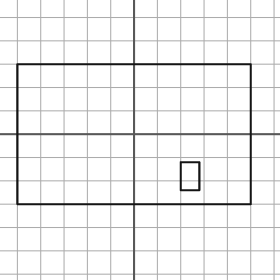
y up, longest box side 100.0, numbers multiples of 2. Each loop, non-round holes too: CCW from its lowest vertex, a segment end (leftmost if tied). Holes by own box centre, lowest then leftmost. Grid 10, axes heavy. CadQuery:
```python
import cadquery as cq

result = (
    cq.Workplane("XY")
    .moveTo(-50.0, -30.0)
    .lineTo(50.0, -30.0)
    .lineTo(50.0, 30.0)
    .lineTo(-50.0, 30.0)
    .close()
    .moveTo(20.0, -24.0)
    .lineTo(28.0, -24.0)
    .lineTo(28.0, -12.0)
    .lineTo(20.0, -12.0)
    .close()
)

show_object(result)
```